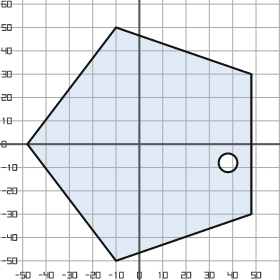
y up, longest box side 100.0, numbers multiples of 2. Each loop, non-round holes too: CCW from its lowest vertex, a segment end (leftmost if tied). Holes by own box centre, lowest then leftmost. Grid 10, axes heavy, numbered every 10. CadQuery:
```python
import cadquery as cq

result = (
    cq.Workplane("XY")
    .moveTo(-10.0, -50.0)
    .lineTo(48.0, -30.0)
    .lineTo(48.0, 30.0)
    .lineTo(-10.0, 50.0)
    .lineTo(-48.0, 0.0)
    .close()
    .moveTo(38.0, -8.0)
    .circle(4.0)
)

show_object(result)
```